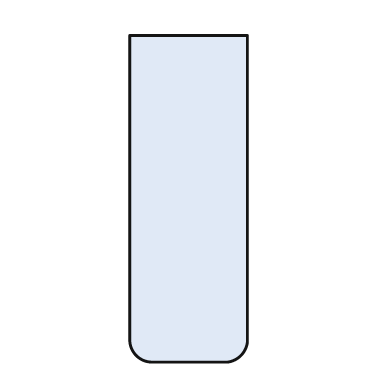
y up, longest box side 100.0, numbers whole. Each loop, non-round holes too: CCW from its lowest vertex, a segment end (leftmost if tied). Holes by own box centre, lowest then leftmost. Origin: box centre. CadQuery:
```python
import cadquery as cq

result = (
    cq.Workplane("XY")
    .moveTo(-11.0, -50.0)
    .lineTo(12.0, -50.0)
    .threePointArc((16.0, -48.0), (18.0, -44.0))
    .lineTo(18.0, 50.0)
    .lineTo(-18.0, 50.0)
    .lineTo(-18.0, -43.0)
    .threePointArc((-16.0, -48.0), (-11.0, -50.0))
    .close()
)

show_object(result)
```